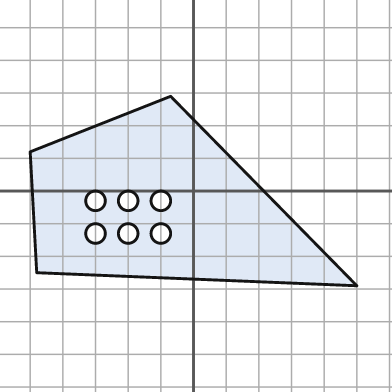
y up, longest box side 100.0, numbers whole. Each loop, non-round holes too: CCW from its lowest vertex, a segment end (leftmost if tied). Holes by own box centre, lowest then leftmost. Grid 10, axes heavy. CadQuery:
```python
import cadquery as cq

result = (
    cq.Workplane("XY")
    .moveTo(50.0, -29.0)
    .lineTo(-7.0, 29.0)
    .lineTo(-50.0, 12.0)
    .lineTo(-48.0, -25.0)
    .close()
    .moveTo(-30.0, -13.0)
    .circle(3.0)
    .moveTo(-20.0, -13.0)
    .circle(3.0)
    .moveTo(-10.0, -13.0)
    .circle(3.0)
    .moveTo(-30.0, -3.0)
    .circle(3.0)
    .moveTo(-20.0, -3.0)
    .circle(3.0)
    .moveTo(-10.0, -3.0)
    .circle(3.0)
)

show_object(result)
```